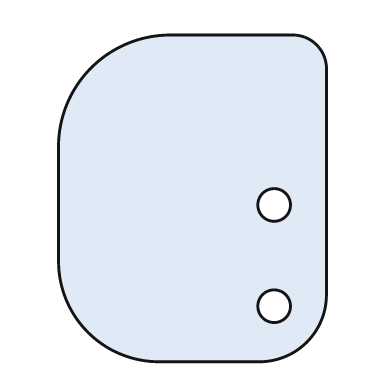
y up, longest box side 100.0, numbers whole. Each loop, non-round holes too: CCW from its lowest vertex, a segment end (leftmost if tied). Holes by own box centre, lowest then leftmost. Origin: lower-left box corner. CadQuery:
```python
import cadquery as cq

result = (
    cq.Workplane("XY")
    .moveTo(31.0, 0.0)
    .lineTo(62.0, 0.0)
    .threePointArc((76.0, 6.0), (82.0, 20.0))
    .lineTo(82.0, 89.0)
    .threePointArc((79.0, 97.0), (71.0, 100.0))
    .lineTo(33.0, 100.0)
    .threePointArc((10.0, 90.0), (0.0, 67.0))
    .lineTo(0.0, 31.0)
    .threePointArc((9.0, 9.0), (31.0, 0.0))
    .close()
    .moveTo(66.0, 17.0)
    .circle(5.0)
    .moveTo(66.0, 48.0)
    .circle(5.0)
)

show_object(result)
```